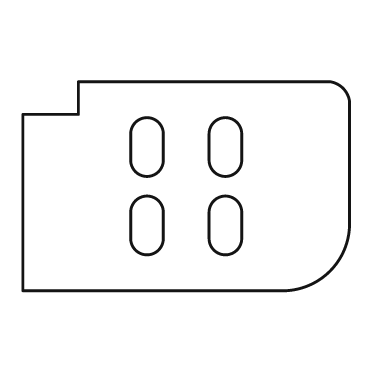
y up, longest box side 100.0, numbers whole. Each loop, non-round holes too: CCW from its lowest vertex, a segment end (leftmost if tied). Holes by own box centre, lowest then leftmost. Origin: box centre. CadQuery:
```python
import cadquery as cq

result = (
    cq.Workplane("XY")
    .moveTo(-50.0, -32.0)
    .lineTo(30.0, -32.0)
    .threePointArc((44.0, -26.0), (50.0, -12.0))
    .lineTo(50.0, 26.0)
    .threePointArc((48.0, 30.0), (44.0, 32.0))
    .lineTo(-33.0, 32.0)
    .lineTo(-33.0, 22.0)
    .lineTo(-50.0, 22.0)
    .close()
    .moveTo(-17.0, -16.0)
    .threePointArc((-12.0, -21.0), (-7.0, -16.0))
    .lineTo(-7.0, -8.0)
    .threePointArc((-12.0, -3.0), (-17.0, -8.0))
    .close()
    .moveTo(7.0, -16.0)
    .threePointArc((12.0, -21.0), (17.0, -16.0))
    .lineTo(17.0, -8.0)
    .threePointArc((12.0, -3.0), (7.0, -8.0))
    .close()
    .moveTo(-17.0, 8.0)
    .threePointArc((-12.0, 3.0), (-7.0, 8.0))
    .lineTo(-7.0, 16.0)
    .threePointArc((-12.0, 21.0), (-17.0, 16.0))
    .close()
    .moveTo(7.0, 8.0)
    .threePointArc((12.0, 3.0), (17.0, 8.0))
    .lineTo(17.0, 16.0)
    .threePointArc((12.0, 21.0), (7.0, 16.0))
    .close()
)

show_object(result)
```